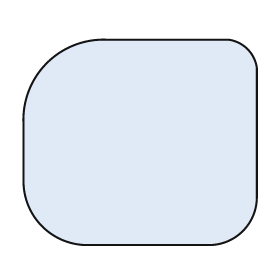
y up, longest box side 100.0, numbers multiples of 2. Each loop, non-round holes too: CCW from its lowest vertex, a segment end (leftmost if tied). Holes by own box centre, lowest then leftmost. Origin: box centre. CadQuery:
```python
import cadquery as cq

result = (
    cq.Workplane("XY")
    .moveTo(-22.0, -44.0)
    .lineTo(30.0, -44.0)
    .threePointArc((44.0, -38.0), (50.0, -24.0))
    .lineTo(50.0, 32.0)
    .threePointArc((46.0, 40.0), (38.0, 44.0))
    .lineTo(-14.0, 44.0)
    .threePointArc((-40.0, 34.0), (-50.0, 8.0))
    .lineTo(-50.0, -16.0)
    .threePointArc((-42.0, -36.0), (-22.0, -44.0))
    .close()
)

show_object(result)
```